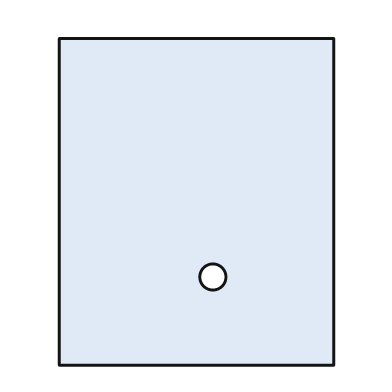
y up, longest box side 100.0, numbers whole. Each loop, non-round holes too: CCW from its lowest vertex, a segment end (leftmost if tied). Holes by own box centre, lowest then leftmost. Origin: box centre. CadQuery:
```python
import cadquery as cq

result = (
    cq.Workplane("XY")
    .moveTo(-42.0, -50.0)
    .lineTo(42.0, -50.0)
    .lineTo(42.0, 50.0)
    .lineTo(-42.0, 50.0)
    .close()
    .moveTo(5.0, -23.0)
    .circle(4.0)
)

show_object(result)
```